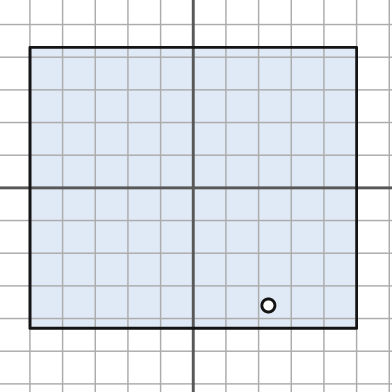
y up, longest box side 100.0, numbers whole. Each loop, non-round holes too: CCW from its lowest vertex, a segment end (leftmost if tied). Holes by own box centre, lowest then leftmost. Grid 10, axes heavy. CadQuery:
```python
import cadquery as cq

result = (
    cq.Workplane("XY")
    .moveTo(-50.0, -43.0)
    .lineTo(50.0, -43.0)
    .lineTo(50.0, 43.0)
    .lineTo(-50.0, 43.0)
    .close()
    .moveTo(23.0, -36.0)
    .circle(2.0)
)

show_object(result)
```